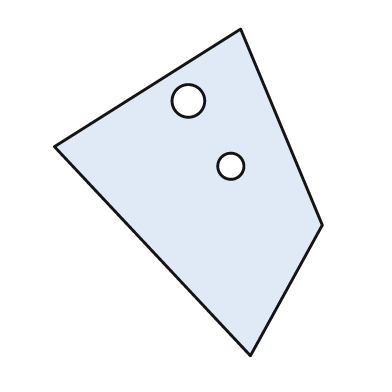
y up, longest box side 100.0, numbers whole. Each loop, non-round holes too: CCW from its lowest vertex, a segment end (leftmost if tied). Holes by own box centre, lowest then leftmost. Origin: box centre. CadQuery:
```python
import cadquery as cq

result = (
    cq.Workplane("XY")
    .moveTo(19.0, -50.0)
    .lineTo(41.0, -10.0)
    .lineTo(16.0, 50.0)
    .lineTo(-41.0, 14.0)
    .close()
    .moveTo(13.0, 8.0)
    .circle(4.0)
    .moveTo(0.0, 28.0)
    .circle(5.0)
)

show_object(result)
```